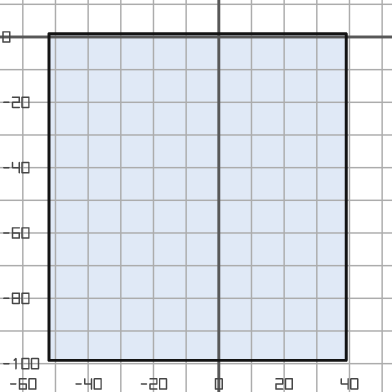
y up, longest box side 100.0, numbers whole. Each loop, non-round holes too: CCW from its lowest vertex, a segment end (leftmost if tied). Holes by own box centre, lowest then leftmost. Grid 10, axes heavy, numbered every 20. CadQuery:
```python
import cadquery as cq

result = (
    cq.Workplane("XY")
    .moveTo(-52.0, -99.0)
    .lineTo(39.0, -99.0)
    .lineTo(39.0, 1.0)
    .lineTo(-52.0, 1.0)
    .close()
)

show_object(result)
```